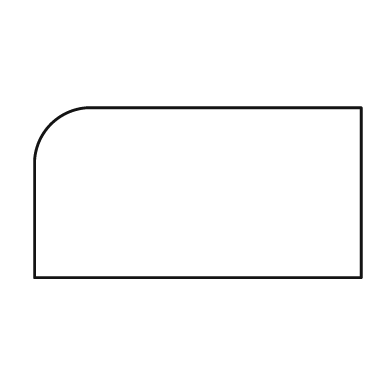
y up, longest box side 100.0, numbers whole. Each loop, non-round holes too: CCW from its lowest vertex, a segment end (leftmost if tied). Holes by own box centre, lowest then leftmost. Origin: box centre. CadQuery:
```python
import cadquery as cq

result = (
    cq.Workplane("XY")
    .moveTo(-50.0, -26.0)
    .lineTo(50.0, -26.0)
    .lineTo(50.0, 26.0)
    .lineTo(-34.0, 26.0)
    .threePointArc((-45.0, 21.0), (-50.0, 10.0))
    .close()
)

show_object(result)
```